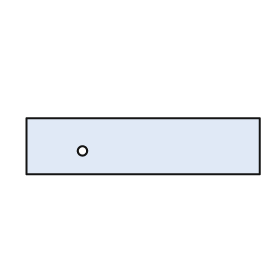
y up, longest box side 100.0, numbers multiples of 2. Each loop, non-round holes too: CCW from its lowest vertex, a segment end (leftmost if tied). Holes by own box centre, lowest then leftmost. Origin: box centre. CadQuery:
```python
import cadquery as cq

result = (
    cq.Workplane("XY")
    .moveTo(-50.0, -12.0)
    .lineTo(50.0, -12.0)
    .lineTo(50.0, 12.0)
    .lineTo(-50.0, 12.0)
    .close()
    .moveTo(-26.0, -2.0)
    .circle(2.0)
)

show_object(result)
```